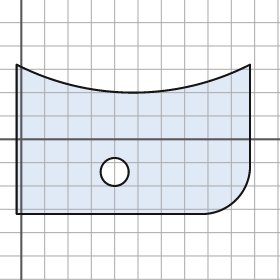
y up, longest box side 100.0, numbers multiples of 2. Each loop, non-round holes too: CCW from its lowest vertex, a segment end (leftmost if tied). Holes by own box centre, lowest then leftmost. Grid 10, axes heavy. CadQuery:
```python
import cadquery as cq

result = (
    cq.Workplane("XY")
    .moveTo(-2.0, -32.0)
    .lineTo(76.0, -32.0)
    .threePointArc((92.0, -26.0), (98.0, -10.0))
    .lineTo(98.0, 32.0)
    .threePointArc((48.0, 20.0), (-2.0, 32.0))
    .close()
    .moveTo(40.0, -14.0)
    .circle(6.0)
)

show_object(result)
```